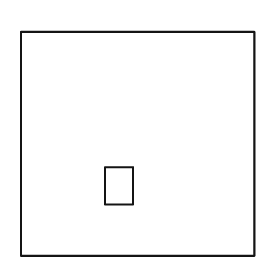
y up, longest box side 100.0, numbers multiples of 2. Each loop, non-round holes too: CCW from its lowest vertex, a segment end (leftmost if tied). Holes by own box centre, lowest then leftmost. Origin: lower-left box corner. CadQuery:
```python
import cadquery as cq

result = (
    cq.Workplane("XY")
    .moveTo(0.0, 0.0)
    .lineTo(100.0, 0.0)
    .lineTo(100.0, 96.0)
    .lineTo(0.0, 96.0)
    .close()
    .moveTo(36.0, 22.0)
    .lineTo(48.0, 22.0)
    .lineTo(48.0, 38.0)
    .lineTo(36.0, 38.0)
    .close()
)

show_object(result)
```